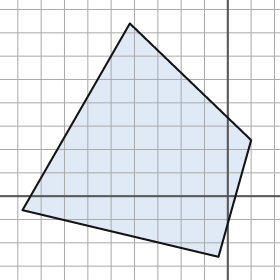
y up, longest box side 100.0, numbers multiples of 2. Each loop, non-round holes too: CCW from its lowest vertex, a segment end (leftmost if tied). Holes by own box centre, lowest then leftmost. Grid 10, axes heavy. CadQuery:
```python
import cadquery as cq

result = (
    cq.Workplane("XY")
    .moveTo(-4.0, -26.0)
    .lineTo(10.0, 24.0)
    .lineTo(-42.0, 74.0)
    .lineTo(-88.0, -6.0)
    .close()
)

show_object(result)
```